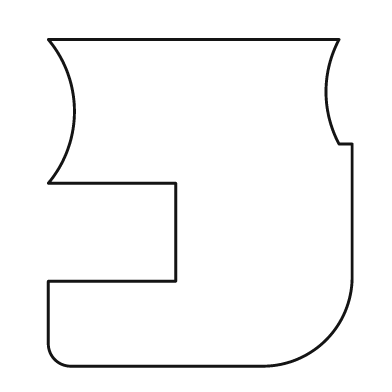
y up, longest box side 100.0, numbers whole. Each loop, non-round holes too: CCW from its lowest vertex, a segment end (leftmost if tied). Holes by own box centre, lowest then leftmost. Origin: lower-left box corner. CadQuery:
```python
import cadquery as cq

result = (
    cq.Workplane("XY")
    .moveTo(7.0, 0.0)
    .lineTo(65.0, 0.0)
    .threePointArc((85.0, 8.0), (93.0, 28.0))
    .lineTo(93.0, 68.0)
    .lineTo(89.0, 68.0)
    .threePointArc((85.0, 84.0), (89.0, 100.0))
    .lineTo(0.0, 100.0)
    .threePointArc((8.0, 78.0), (0.0, 56.0))
    .lineTo(39.0, 56.0)
    .lineTo(39.0, 26.0)
    .lineTo(0.0, 26.0)
    .lineTo(0.0, 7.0)
    .threePointArc((2.0, 2.0), (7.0, 0.0))
    .close()
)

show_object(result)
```